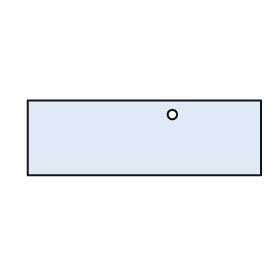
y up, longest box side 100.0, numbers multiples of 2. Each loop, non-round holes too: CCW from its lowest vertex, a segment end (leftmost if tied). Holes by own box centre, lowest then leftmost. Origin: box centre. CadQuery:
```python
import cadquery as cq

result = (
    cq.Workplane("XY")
    .moveTo(-50.0, -16.0)
    .lineTo(50.0, -16.0)
    .lineTo(50.0, 16.0)
    .lineTo(-50.0, 16.0)
    .close()
    .moveTo(12.0, 10.0)
    .circle(2.0)
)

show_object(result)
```